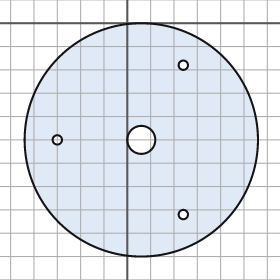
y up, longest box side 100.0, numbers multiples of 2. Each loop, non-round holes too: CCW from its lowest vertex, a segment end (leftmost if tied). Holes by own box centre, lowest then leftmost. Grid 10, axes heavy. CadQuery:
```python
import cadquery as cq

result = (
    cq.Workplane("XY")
    .moveTo(6.0, -50.0)
    .circle(50.0)
    .moveTo(24.0, -82.0)
    .circle(2.0)
    .moveTo(-30.0, -50.0)
    .circle(2.0)
    .moveTo(6.0, -50.0)
    .circle(6.0)
    .moveTo(24.0, -18.0)
    .circle(2.0)
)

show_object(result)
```